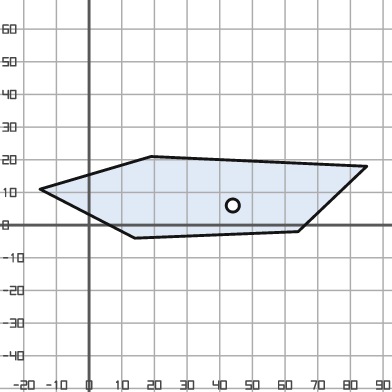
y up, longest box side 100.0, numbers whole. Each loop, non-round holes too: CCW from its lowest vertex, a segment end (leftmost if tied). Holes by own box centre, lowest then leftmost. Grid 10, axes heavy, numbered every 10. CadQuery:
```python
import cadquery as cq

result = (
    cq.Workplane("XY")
    .moveTo(14.0, -4.0)
    .lineTo(64.0, -2.0)
    .lineTo(85.0, 18.0)
    .lineTo(19.0, 21.0)
    .lineTo(-15.0, 11.0)
    .close()
    .moveTo(44.0, 6.0)
    .circle(2.0)
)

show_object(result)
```